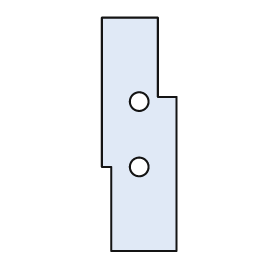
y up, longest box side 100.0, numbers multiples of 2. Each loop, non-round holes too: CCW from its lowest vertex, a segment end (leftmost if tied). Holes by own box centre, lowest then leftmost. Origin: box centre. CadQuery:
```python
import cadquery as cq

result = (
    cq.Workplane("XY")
    .moveTo(-12.0, -50.0)
    .lineTo(16.0, -50.0)
    .lineTo(16.0, 16.0)
    .lineTo(8.0, 16.0)
    .lineTo(8.0, 50.0)
    .lineTo(-16.0, 50.0)
    .lineTo(-16.0, -14.0)
    .lineTo(-12.0, -14.0)
    .close()
    .moveTo(0.0, -14.0)
    .circle(4.0)
    .moveTo(0.0, 14.0)
    .circle(4.0)
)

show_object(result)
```